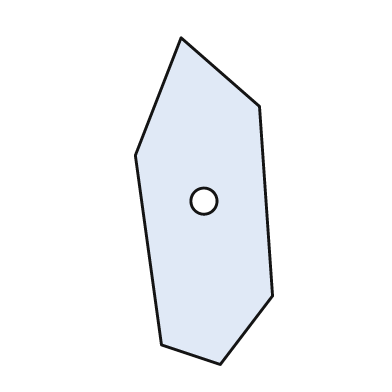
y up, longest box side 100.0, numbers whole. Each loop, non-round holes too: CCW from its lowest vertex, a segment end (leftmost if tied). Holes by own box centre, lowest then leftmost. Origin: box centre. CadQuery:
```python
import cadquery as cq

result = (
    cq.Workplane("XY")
    .moveTo(5.0, -50.0)
    .lineTo(21.0, -29.0)
    .lineTo(17.0, 29.0)
    .lineTo(-7.0, 50.0)
    .lineTo(-21.0, 14.0)
    .lineTo(-13.0, -44.0)
    .close()
    .moveTo(0.0, 0.0)
    .circle(4.0)
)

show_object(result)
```